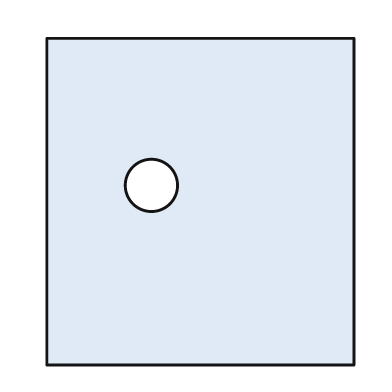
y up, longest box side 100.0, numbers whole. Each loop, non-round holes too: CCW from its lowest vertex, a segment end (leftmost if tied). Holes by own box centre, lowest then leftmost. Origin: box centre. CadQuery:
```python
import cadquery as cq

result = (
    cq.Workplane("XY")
    .moveTo(-47.0, -50.0)
    .lineTo(47.0, -50.0)
    .lineTo(47.0, 50.0)
    .lineTo(-47.0, 50.0)
    .close()
    .moveTo(-15.0, 5.0)
    .circle(8.0)
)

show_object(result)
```